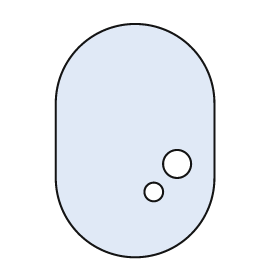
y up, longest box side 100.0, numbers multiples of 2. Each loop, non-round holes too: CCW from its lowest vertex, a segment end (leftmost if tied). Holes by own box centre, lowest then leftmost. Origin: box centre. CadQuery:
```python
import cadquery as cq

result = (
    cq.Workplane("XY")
    .moveTo(-34.0, -16.0)
    .threePointArc((0.0, -50.0), (34.0, -16.0))
    .lineTo(34.0, 16.0)
    .threePointArc((0.0, 50.0), (-34.0, 16.0))
    .close()
    .moveTo(8.0, -22.0)
    .circle(4.0)
    .moveTo(18.0, -10.0)
    .circle(6.0)
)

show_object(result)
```